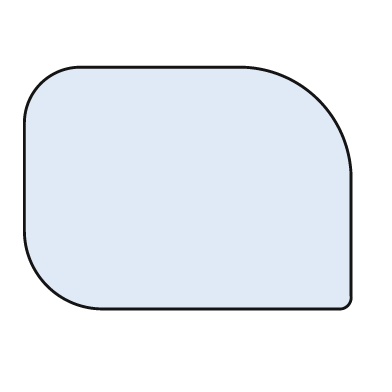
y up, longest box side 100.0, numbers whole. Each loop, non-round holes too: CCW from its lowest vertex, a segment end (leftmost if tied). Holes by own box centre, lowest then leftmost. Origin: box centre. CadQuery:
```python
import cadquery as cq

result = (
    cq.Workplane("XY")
    .moveTo(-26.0, -37.0)
    .lineTo(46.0, -37.0)
    .threePointArc((49.0, -36.0), (50.0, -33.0))
    .lineTo(50.0, 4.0)
    .threePointArc((40.0, 27.0), (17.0, 37.0))
    .lineTo(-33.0, 37.0)
    .threePointArc((-45.0, 32.0), (-50.0, 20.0))
    .lineTo(-50.0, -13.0)
    .threePointArc((-43.0, -30.0), (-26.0, -37.0))
    .close()
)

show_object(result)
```